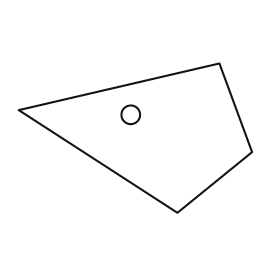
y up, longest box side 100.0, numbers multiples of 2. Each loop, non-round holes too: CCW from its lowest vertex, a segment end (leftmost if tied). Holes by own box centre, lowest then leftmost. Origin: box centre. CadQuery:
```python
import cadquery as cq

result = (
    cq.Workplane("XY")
    .moveTo(18.0, -32.0)
    .lineTo(50.0, -6.0)
    .lineTo(36.0, 32.0)
    .lineTo(-50.0, 12.0)
    .close()
    .moveTo(-2.0, 10.0)
    .circle(4.0)
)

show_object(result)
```